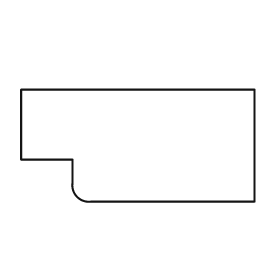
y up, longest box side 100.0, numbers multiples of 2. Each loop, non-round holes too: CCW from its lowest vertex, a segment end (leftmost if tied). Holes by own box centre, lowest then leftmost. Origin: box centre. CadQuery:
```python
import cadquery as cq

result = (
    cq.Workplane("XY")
    .moveTo(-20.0, -24.0)
    .lineTo(50.0, -24.0)
    .lineTo(50.0, 24.0)
    .lineTo(-50.0, 24.0)
    .lineTo(-50.0, -6.0)
    .lineTo(-28.0, -6.0)
    .lineTo(-28.0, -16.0)
    .threePointArc((-26.0, -22.0), (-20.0, -24.0))
    .close()
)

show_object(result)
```